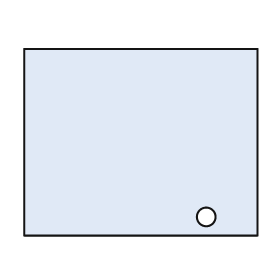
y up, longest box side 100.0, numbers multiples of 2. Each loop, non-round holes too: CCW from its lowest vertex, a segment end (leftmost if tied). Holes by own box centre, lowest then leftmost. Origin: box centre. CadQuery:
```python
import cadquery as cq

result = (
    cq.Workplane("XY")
    .moveTo(-50.0, -40.0)
    .lineTo(50.0, -40.0)
    .lineTo(50.0, 40.0)
    .lineTo(-50.0, 40.0)
    .close()
    .moveTo(28.0, -32.0)
    .circle(4.0)
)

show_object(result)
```